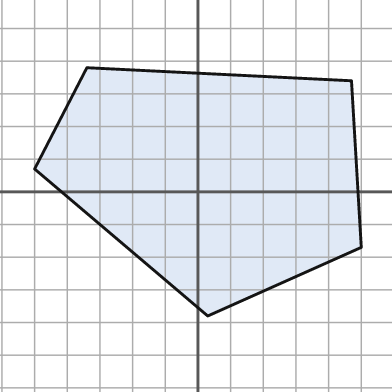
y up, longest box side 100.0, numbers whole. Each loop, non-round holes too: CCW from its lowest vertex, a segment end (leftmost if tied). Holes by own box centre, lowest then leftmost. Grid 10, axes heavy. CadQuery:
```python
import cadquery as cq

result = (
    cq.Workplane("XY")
    .moveTo(3.0, -38.0)
    .lineTo(50.0, -17.0)
    .lineTo(47.0, 34.0)
    .lineTo(-34.0, 38.0)
    .lineTo(-50.0, 7.0)
    .close()
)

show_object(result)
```